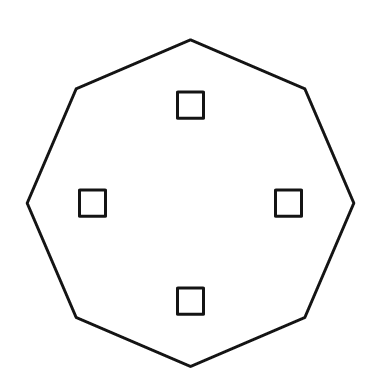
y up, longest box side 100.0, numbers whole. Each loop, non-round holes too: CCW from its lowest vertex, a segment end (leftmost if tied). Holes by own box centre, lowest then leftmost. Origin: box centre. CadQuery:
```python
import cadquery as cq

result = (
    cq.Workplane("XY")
    .moveTo(0.0, -50.0)
    .lineTo(35.0, -35.0)
    .lineTo(50.0, 0.0)
    .lineTo(35.0, 35.0)
    .lineTo(0.0, 50.0)
    .lineTo(-35.0, 35.0)
    .lineTo(-50.0, 0.0)
    .lineTo(-35.0, -35.0)
    .close()
    .moveTo(-4.0, -34.0)
    .lineTo(4.0, -34.0)
    .lineTo(4.0, -26.0)
    .lineTo(-4.0, -26.0)
    .close()
    .moveTo(-34.0, -4.0)
    .lineTo(-26.0, -4.0)
    .lineTo(-26.0, 4.0)
    .lineTo(-34.0, 4.0)
    .close()
    .moveTo(26.0, -4.0)
    .lineTo(34.0, -4.0)
    .lineTo(34.0, 4.0)
    .lineTo(26.0, 4.0)
    .close()
    .moveTo(-4.0, 26.0)
    .lineTo(4.0, 26.0)
    .lineTo(4.0, 34.0)
    .lineTo(-4.0, 34.0)
    .close()
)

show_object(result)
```